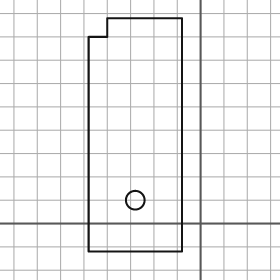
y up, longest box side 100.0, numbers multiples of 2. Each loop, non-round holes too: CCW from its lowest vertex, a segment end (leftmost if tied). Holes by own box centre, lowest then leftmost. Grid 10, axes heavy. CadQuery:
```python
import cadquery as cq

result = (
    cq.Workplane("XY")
    .moveTo(-48.0, -12.0)
    .lineTo(-8.0, -12.0)
    .lineTo(-8.0, 88.0)
    .lineTo(-40.0, 88.0)
    .lineTo(-40.0, 80.0)
    .lineTo(-48.0, 80.0)
    .close()
    .moveTo(-28.0, 10.0)
    .circle(4.0)
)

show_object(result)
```